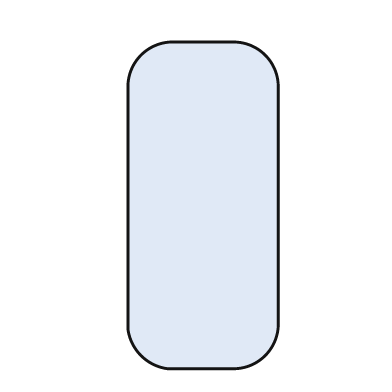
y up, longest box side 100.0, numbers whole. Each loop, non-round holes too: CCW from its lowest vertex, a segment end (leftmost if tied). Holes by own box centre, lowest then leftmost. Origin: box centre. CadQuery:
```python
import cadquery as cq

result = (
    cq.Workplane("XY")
    .moveTo(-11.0, -50.0)
    .lineTo(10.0, -50.0)
    .threePointArc((19.0, -46.0), (23.0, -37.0))
    .lineTo(23.0, 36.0)
    .threePointArc((19.0, 46.0), (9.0, 50.0))
    .lineTo(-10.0, 50.0)
    .threePointArc((-19.0, 46.0), (-23.0, 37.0))
    .lineTo(-23.0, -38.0)
    .threePointArc((-19.0, -46.0), (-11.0, -50.0))
    .close()
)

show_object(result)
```